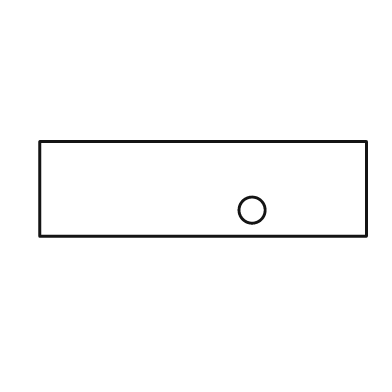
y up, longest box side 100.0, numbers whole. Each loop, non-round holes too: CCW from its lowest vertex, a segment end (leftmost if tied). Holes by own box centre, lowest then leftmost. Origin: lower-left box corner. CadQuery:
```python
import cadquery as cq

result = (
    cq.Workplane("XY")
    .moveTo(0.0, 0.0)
    .lineTo(100.0, 0.0)
    .lineTo(100.0, 29.0)
    .lineTo(0.0, 29.0)
    .close()
    .moveTo(65.0, 8.0)
    .circle(4.0)
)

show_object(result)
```